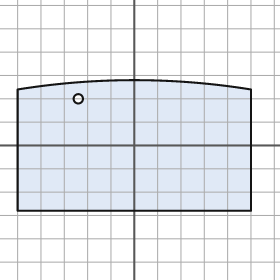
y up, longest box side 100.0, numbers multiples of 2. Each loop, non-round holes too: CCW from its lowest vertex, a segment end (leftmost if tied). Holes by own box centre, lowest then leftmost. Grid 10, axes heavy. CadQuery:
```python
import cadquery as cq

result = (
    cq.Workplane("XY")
    .moveTo(-50.0, -28.0)
    .lineTo(50.0, -28.0)
    .lineTo(50.0, 24.0)
    .threePointArc((0.0, 28.0), (-50.0, 24.0))
    .close()
    .moveTo(-24.0, 20.0)
    .circle(2.0)
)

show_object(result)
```